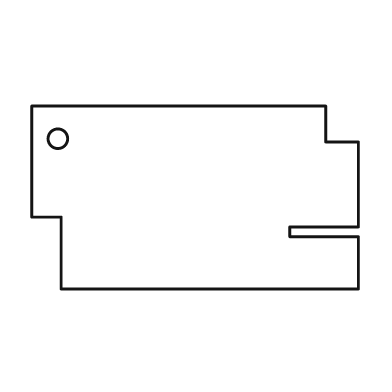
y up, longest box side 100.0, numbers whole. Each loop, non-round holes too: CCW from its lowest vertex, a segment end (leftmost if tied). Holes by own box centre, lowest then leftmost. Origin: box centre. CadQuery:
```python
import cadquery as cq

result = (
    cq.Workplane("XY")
    .moveTo(-41.0, -28.0)
    .lineTo(50.0, -28.0)
    .lineTo(50.0, -12.0)
    .lineTo(29.0, -12.0)
    .lineTo(29.0, -9.0)
    .lineTo(50.0, -9.0)
    .lineTo(50.0, 17.0)
    .lineTo(40.0, 17.0)
    .lineTo(40.0, 28.0)
    .lineTo(-50.0, 28.0)
    .lineTo(-50.0, -6.0)
    .lineTo(-41.0, -6.0)
    .close()
    .moveTo(-42.0, 18.0)
    .circle(3.0)
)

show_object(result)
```